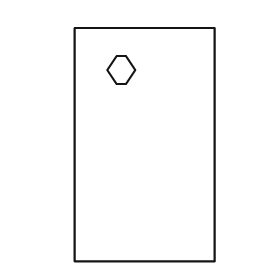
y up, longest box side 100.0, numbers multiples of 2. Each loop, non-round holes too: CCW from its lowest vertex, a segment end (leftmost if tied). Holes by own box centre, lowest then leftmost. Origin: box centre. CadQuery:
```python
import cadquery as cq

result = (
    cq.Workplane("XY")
    .moveTo(-30.0, -50.0)
    .lineTo(30.0, -50.0)
    .lineTo(30.0, 50.0)
    .lineTo(-30.0, 50.0)
    .close()
    .moveTo(-12.0, 26.0)
    .lineTo(-8.0, 26.0)
    .lineTo(-4.0, 32.0)
    .lineTo(-8.0, 38.0)
    .lineTo(-12.0, 38.0)
    .lineTo(-16.0, 32.0)
    .close()
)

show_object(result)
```